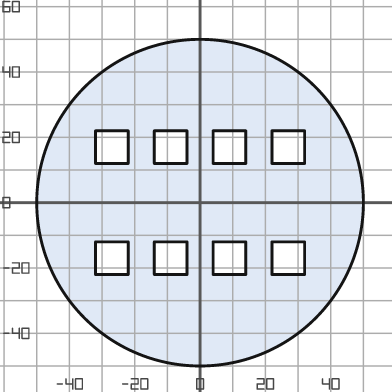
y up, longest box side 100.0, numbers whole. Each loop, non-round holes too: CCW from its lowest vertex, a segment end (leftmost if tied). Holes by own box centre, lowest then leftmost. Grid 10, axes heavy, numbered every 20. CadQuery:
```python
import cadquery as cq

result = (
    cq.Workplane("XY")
    .moveTo(0.0, 0.0)
    .circle(50.0)
    .moveTo(-32.0, -22.0)
    .lineTo(-22.0, -22.0)
    .lineTo(-22.0, -12.0)
    .lineTo(-32.0, -12.0)
    .close()
    .moveTo(-14.0, -22.0)
    .lineTo(-4.0, -22.0)
    .lineTo(-4.0, -12.0)
    .lineTo(-14.0, -12.0)
    .close()
    .moveTo(4.0, -22.0)
    .lineTo(14.0, -22.0)
    .lineTo(14.0, -12.0)
    .lineTo(4.0, -12.0)
    .close()
    .moveTo(22.0, -22.0)
    .lineTo(32.0, -22.0)
    .lineTo(32.0, -12.0)
    .lineTo(22.0, -12.0)
    .close()
    .moveTo(-32.0, 12.0)
    .lineTo(-22.0, 12.0)
    .lineTo(-22.0, 22.0)
    .lineTo(-32.0, 22.0)
    .close()
    .moveTo(-14.0, 12.0)
    .lineTo(-4.0, 12.0)
    .lineTo(-4.0, 22.0)
    .lineTo(-14.0, 22.0)
    .close()
    .moveTo(4.0, 12.0)
    .lineTo(14.0, 12.0)
    .lineTo(14.0, 22.0)
    .lineTo(4.0, 22.0)
    .close()
    .moveTo(22.0, 12.0)
    .lineTo(32.0, 12.0)
    .lineTo(32.0, 22.0)
    .lineTo(22.0, 22.0)
    .close()
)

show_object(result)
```